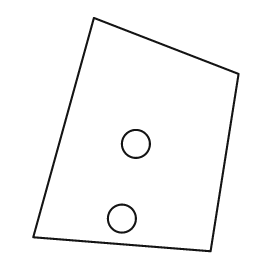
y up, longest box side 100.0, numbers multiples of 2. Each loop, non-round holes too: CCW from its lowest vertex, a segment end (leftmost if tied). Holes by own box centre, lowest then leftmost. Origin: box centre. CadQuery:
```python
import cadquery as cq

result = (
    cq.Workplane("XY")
    .moveTo(32.0, -50.0)
    .lineTo(44.0, 26.0)
    .lineTo(-18.0, 50.0)
    .lineTo(-44.0, -44.0)
    .close()
    .moveTo(-6.0, -36.0)
    .circle(6.0)
    .moveTo(0.0, -4.0)
    .circle(6.0)
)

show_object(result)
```